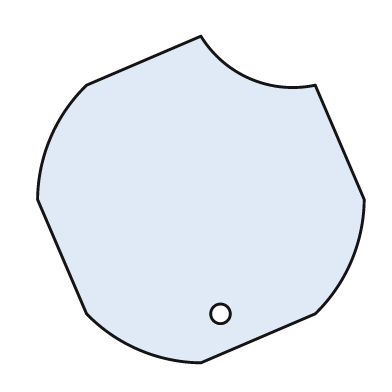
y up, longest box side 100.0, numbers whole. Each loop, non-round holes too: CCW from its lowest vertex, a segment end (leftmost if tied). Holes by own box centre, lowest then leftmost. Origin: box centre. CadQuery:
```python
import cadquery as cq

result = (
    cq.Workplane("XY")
    .moveTo(0.0, -50.0)
    .lineTo(35.0, -35.0)
    .threePointArc((46.0, -19.0), (50.0, 0.0))
    .lineTo(35.0, 35.0)
    .threePointArc((15.0, 37.0), (0.0, 50.0))
    .lineTo(-35.0, 35.0)
    .threePointArc((-46.0, 19.0), (-50.0, 0.0))
    .lineTo(-35.0, -35.0)
    .threePointArc((-19.0, -46.0), (0.0, -50.0))
    .close()
    .moveTo(6.0, -35.0)
    .circle(3.0)
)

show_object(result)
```